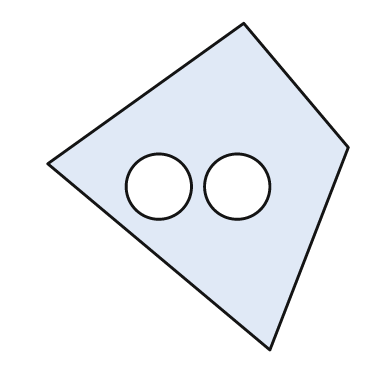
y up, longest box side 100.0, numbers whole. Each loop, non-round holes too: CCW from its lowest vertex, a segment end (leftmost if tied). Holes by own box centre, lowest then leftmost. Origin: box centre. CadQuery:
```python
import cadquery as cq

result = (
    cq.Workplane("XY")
    .moveTo(22.0, -50.0)
    .lineTo(46.0, 12.0)
    .lineTo(14.0, 50.0)
    .lineTo(-46.0, 7.0)
    .close()
    .moveTo(-12.0, 0.0)
    .circle(10.0)
    .moveTo(12.0, 0.0)
    .circle(10.0)
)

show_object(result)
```